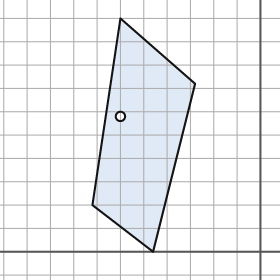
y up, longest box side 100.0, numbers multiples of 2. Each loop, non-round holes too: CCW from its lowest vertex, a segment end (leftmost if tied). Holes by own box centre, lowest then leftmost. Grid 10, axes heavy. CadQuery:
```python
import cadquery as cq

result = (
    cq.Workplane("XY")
    .moveTo(-46.0, 0.0)
    .lineTo(-28.0, 72.0)
    .lineTo(-60.0, 100.0)
    .lineTo(-72.0, 20.0)
    .close()
    .moveTo(-60.0, 58.0)
    .circle(2.0)
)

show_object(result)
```